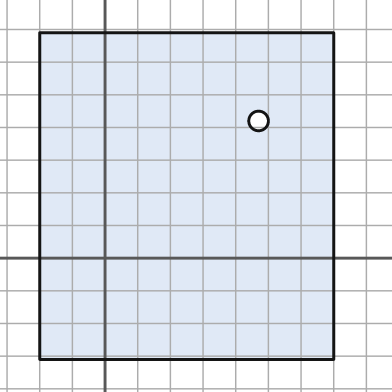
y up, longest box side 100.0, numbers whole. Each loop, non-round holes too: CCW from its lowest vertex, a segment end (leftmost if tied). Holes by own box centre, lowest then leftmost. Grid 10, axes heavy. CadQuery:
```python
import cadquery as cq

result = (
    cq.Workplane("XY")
    .moveTo(-20.0, -31.0)
    .lineTo(70.0, -31.0)
    .lineTo(70.0, 69.0)
    .lineTo(-20.0, 69.0)
    .close()
    .moveTo(47.0, 42.0)
    .circle(3.0)
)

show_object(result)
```